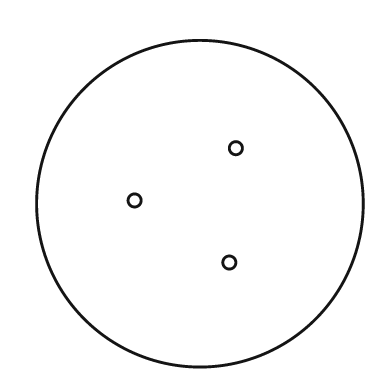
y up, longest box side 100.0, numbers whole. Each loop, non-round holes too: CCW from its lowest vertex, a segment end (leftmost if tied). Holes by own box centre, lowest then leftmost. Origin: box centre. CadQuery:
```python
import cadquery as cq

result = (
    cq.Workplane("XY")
    .moveTo(0.0, 0.0)
    .circle(50.0)
    .moveTo(9.0, -18.0)
    .circle(2.0)
    .moveTo(-20.0, 1.0)
    .circle(2.0)
    .moveTo(11.0, 17.0)
    .circle(2.0)
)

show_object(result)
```